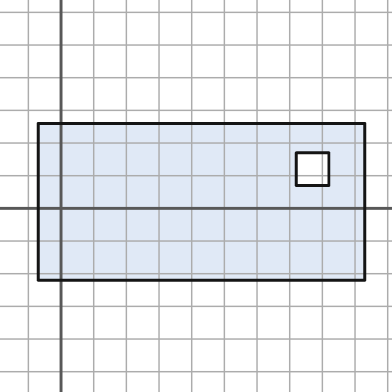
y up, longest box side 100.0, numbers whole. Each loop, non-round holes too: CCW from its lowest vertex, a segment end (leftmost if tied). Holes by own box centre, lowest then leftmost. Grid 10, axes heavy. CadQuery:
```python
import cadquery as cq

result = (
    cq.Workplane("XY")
    .moveTo(-7.0, -22.0)
    .lineTo(93.0, -22.0)
    .lineTo(93.0, 26.0)
    .lineTo(-7.0, 26.0)
    .close()
    .moveTo(72.0, 7.0)
    .lineTo(82.0, 7.0)
    .lineTo(82.0, 17.0)
    .lineTo(72.0, 17.0)
    .close()
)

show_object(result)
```